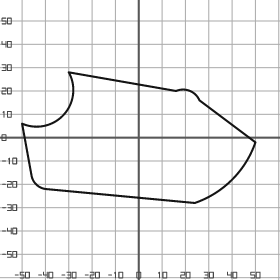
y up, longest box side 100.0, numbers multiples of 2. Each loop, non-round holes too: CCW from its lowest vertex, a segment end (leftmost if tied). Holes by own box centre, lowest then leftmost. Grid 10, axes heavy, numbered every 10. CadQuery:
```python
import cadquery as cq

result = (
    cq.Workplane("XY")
    .moveTo(24.0, -28.0)
    .threePointArc((40.0, -18.0), (50.0, -2.0))
    .lineTo(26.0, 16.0)
    .threePointArc((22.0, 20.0), (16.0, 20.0))
    .lineTo(-30.0, 28.0)
    .threePointArc((-32.0, 10.0), (-50.0, 6.0))
    .lineTo(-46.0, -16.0)
    .threePointArc((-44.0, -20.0), (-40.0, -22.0))
    .close()
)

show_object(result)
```